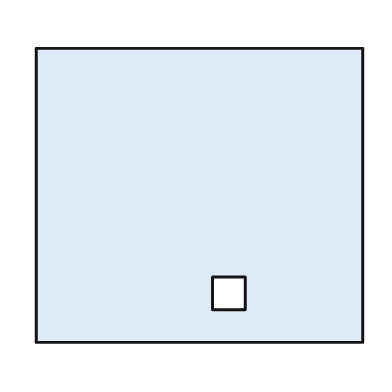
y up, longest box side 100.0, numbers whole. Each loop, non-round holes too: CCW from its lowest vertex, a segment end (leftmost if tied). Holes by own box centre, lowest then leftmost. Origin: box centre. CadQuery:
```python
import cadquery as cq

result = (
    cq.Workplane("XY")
    .moveTo(-50.0, -45.0)
    .lineTo(50.0, -45.0)
    .lineTo(50.0, 45.0)
    .lineTo(-50.0, 45.0)
    .close()
    .moveTo(4.0, -35.0)
    .lineTo(14.0, -35.0)
    .lineTo(14.0, -25.0)
    .lineTo(4.0, -25.0)
    .close()
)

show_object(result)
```